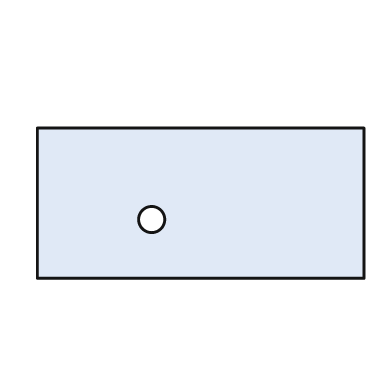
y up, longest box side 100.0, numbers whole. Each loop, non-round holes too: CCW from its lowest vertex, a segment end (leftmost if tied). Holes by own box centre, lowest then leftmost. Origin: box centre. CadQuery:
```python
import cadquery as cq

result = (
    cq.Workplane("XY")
    .moveTo(-50.0, -23.0)
    .lineTo(50.0, -23.0)
    .lineTo(50.0, 23.0)
    .lineTo(-50.0, 23.0)
    .close()
    .moveTo(-15.0, -5.0)
    .circle(4.0)
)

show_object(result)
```